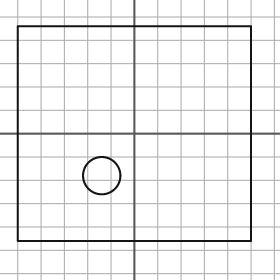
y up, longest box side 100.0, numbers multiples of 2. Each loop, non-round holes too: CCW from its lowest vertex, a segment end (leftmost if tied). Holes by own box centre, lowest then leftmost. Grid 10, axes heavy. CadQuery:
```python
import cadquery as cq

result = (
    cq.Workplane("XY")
    .moveTo(-50.0, -46.0)
    .lineTo(50.0, -46.0)
    .lineTo(50.0, 46.0)
    .lineTo(-50.0, 46.0)
    .close()
    .moveTo(-14.0, -18.0)
    .circle(8.0)
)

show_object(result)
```